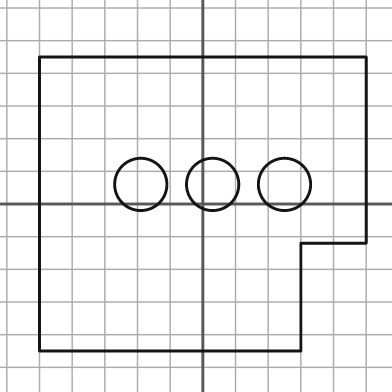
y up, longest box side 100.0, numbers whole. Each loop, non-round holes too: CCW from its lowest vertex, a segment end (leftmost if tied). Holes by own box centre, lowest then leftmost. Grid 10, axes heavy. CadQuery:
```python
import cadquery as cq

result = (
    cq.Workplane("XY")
    .moveTo(-50.0, -45.0)
    .lineTo(30.0, -45.0)
    .lineTo(30.0, -12.0)
    .lineTo(50.0, -12.0)
    .lineTo(50.0, 45.0)
    .lineTo(-50.0, 45.0)
    .close()
    .moveTo(-19.0, 6.0)
    .circle(8.0)
    .moveTo(3.0, 6.0)
    .circle(8.0)
    .moveTo(25.0, 6.0)
    .circle(8.0)
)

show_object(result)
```